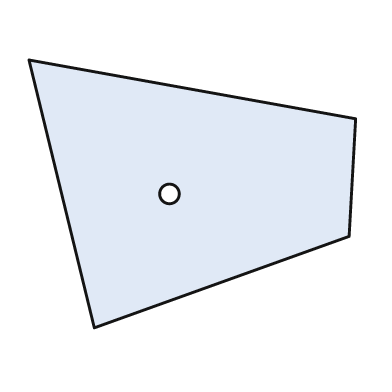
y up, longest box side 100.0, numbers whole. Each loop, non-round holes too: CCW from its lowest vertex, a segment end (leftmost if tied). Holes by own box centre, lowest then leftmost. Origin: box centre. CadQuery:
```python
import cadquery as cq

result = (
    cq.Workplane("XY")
    .moveTo(-30.0, -41.0)
    .lineTo(48.0, -13.0)
    .lineTo(50.0, 23.0)
    .lineTo(-50.0, 41.0)
    .close()
    .moveTo(-7.0, 0.0)
    .circle(3.0)
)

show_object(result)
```